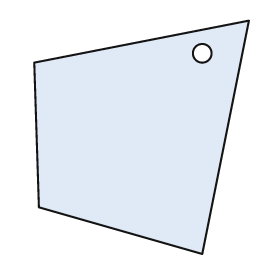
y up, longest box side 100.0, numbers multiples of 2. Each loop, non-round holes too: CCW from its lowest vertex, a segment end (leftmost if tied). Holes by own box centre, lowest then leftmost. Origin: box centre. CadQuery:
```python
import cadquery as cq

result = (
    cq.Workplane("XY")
    .moveTo(26.0, -50.0)
    .lineTo(46.0, 50.0)
    .lineTo(-46.0, 32.0)
    .lineTo(-44.0, -30.0)
    .close()
    .moveTo(26.0, 36.0)
    .circle(4.0)
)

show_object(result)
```